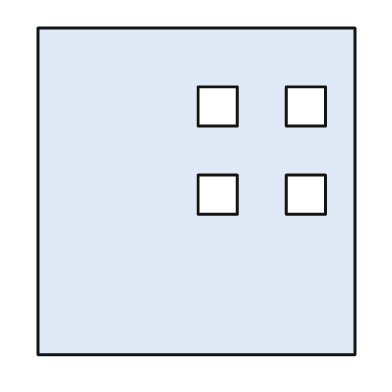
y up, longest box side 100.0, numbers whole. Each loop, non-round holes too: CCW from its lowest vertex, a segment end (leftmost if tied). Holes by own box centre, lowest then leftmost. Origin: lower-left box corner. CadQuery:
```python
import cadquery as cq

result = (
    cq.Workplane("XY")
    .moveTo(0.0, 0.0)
    .lineTo(97.0, 0.0)
    .lineTo(97.0, 100.0)
    .lineTo(0.0, 100.0)
    .close()
    .moveTo(49.0, 43.0)
    .lineTo(61.0, 43.0)
    .lineTo(61.0, 55.0)
    .lineTo(49.0, 55.0)
    .close()
    .moveTo(76.0, 43.0)
    .lineTo(88.0, 43.0)
    .lineTo(88.0, 55.0)
    .lineTo(76.0, 55.0)
    .close()
    .moveTo(49.0, 70.0)
    .lineTo(61.0, 70.0)
    .lineTo(61.0, 82.0)
    .lineTo(49.0, 82.0)
    .close()
    .moveTo(76.0, 70.0)
    .lineTo(88.0, 70.0)
    .lineTo(88.0, 82.0)
    .lineTo(76.0, 82.0)
    .close()
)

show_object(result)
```